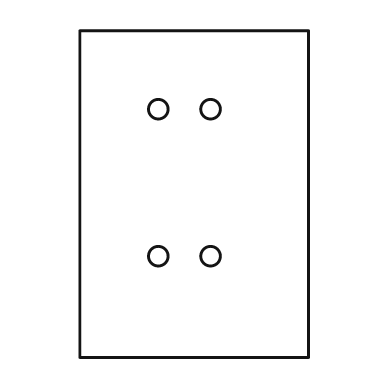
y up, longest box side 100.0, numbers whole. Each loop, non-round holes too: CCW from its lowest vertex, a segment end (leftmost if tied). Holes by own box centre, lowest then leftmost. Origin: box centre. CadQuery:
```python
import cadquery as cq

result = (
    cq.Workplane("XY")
    .moveTo(-35.0, -50.0)
    .lineTo(35.0, -50.0)
    .lineTo(35.0, 50.0)
    .lineTo(-35.0, 50.0)
    .close()
    .moveTo(-11.0, -19.0)
    .circle(3.0)
    .moveTo(5.0, -19.0)
    .circle(3.0)
    .moveTo(-11.0, 26.0)
    .circle(3.0)
    .moveTo(5.0, 26.0)
    .circle(3.0)
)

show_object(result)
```